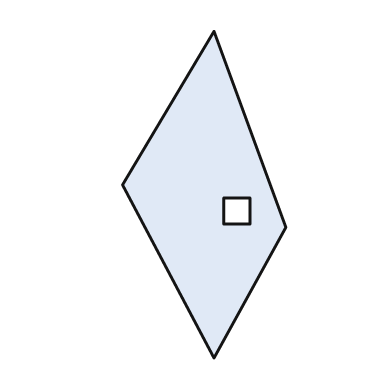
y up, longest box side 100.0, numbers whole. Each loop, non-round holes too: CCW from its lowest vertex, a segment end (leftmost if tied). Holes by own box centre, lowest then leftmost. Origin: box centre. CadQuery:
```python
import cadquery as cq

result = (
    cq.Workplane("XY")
    .moveTo(3.0, -50.0)
    .lineTo(25.0, -10.0)
    .lineTo(3.0, 50.0)
    .lineTo(-25.0, 3.0)
    .close()
    .moveTo(6.0, -9.0)
    .lineTo(14.0, -9.0)
    .lineTo(14.0, -1.0)
    .lineTo(6.0, -1.0)
    .close()
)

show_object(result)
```